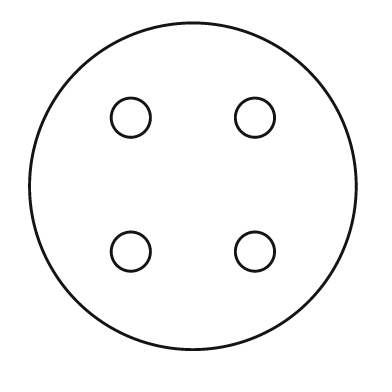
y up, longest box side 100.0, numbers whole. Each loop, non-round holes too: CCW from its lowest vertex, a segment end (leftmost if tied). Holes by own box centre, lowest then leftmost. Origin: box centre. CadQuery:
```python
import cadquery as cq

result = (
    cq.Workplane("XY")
    .moveTo(0.0, 0.0)
    .circle(50.0)
    .moveTo(-19.0, -20.0)
    .circle(6.0)
    .moveTo(19.0, -20.0)
    .circle(6.0)
    .moveTo(-19.0, 21.0)
    .circle(6.0)
    .moveTo(19.0, 21.0)
    .circle(6.0)
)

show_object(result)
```